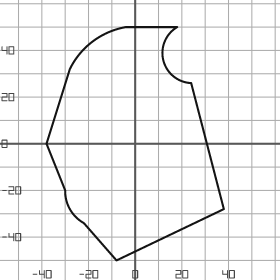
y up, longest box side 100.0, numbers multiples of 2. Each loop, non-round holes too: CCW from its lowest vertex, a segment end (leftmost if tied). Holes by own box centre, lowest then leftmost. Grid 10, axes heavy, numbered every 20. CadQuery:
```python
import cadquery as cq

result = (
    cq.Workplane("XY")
    .moveTo(-8.0, -50.0)
    .lineTo(38.0, -28.0)
    .lineTo(24.0, 26.0)
    .threePointArc((12.0, 36.0), (18.0, 50.0))
    .lineTo(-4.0, 50.0)
    .threePointArc((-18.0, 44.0), (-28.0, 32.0))
    .lineTo(-38.0, 0.0)
    .lineTo(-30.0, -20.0)
    .threePointArc((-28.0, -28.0), (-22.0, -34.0))
    .close()
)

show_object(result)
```